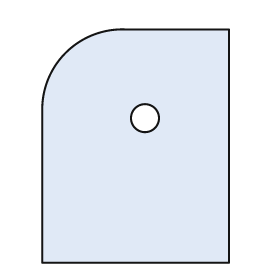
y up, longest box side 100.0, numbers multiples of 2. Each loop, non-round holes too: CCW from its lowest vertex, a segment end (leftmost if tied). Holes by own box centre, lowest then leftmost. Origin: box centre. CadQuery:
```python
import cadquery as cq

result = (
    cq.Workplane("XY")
    .moveTo(-40.0, -50.0)
    .lineTo(40.0, -50.0)
    .lineTo(40.0, 50.0)
    .lineTo(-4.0, 50.0)
    .threePointArc((-30.0, 40.0), (-40.0, 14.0))
    .close()
    .moveTo(4.0, 12.0)
    .circle(6.0)
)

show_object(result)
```